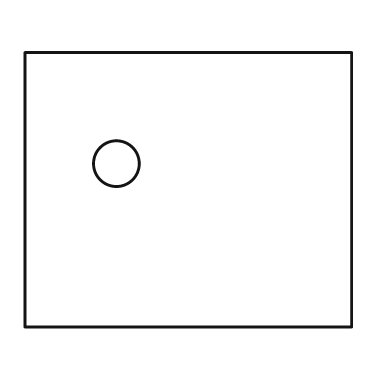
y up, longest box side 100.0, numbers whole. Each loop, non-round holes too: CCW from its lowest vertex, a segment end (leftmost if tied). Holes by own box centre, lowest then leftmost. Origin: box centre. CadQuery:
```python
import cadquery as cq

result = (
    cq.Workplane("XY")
    .moveTo(-50.0, -42.0)
    .lineTo(50.0, -42.0)
    .lineTo(50.0, 42.0)
    .lineTo(-50.0, 42.0)
    .close()
    .moveTo(-22.0, 8.0)
    .circle(7.0)
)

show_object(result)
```